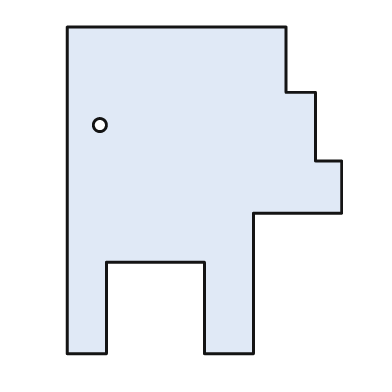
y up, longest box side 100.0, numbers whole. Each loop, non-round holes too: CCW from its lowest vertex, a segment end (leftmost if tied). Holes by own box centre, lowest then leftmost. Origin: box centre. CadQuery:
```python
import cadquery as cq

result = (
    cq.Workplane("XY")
    .moveTo(-42.0, -50.0)
    .lineTo(-30.0, -50.0)
    .lineTo(-30.0, -22.0)
    .lineTo(0.0, -22.0)
    .lineTo(0.0, -50.0)
    .lineTo(15.0, -50.0)
    .lineTo(15.0, -7.0)
    .lineTo(42.0, -7.0)
    .lineTo(42.0, 9.0)
    .lineTo(34.0, 9.0)
    .lineTo(34.0, 30.0)
    .lineTo(25.0, 30.0)
    .lineTo(25.0, 50.0)
    .lineTo(-42.0, 50.0)
    .close()
    .moveTo(-32.0, 20.0)
    .circle(2.0)
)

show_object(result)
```